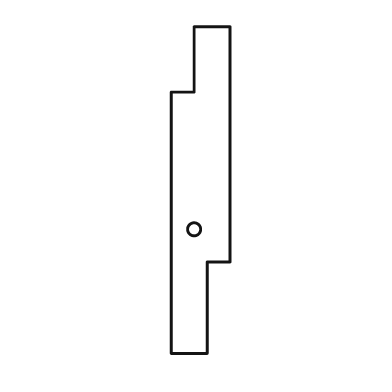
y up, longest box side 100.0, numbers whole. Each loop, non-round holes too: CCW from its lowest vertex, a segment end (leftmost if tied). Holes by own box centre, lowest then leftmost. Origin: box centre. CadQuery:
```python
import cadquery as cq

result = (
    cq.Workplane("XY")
    .moveTo(-9.0, -50.0)
    .lineTo(2.0, -50.0)
    .lineTo(2.0, -22.0)
    .lineTo(9.0, -22.0)
    .lineTo(9.0, 50.0)
    .lineTo(-2.0, 50.0)
    .lineTo(-2.0, 30.0)
    .lineTo(-9.0, 30.0)
    .close()
    .moveTo(-2.0, -12.0)
    .circle(2.0)
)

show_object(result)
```